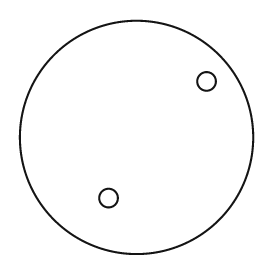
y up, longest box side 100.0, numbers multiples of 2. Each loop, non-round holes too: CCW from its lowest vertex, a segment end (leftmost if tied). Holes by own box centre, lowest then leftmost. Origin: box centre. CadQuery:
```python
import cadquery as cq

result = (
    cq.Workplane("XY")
    .moveTo(0.0, 0.0)
    .circle(50.0)
    .moveTo(-12.0, -26.0)
    .circle(4.0)
    .moveTo(30.0, 24.0)
    .circle(4.0)
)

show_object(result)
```